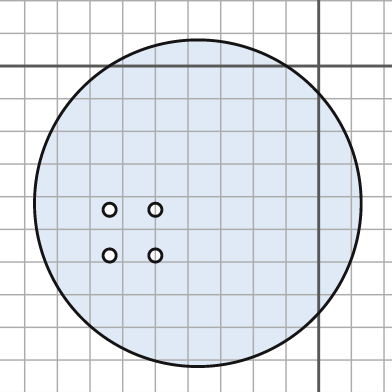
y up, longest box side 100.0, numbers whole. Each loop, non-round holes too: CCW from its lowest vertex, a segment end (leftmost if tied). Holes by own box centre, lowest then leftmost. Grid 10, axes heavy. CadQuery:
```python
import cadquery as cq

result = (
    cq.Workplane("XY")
    .moveTo(-37.0, -42.0)
    .circle(50.0)
    .moveTo(-64.0, -58.0)
    .circle(2.0)
    .moveTo(-50.0, -58.0)
    .circle(2.0)
    .moveTo(-64.0, -44.0)
    .circle(2.0)
    .moveTo(-50.0, -44.0)
    .circle(2.0)
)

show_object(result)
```